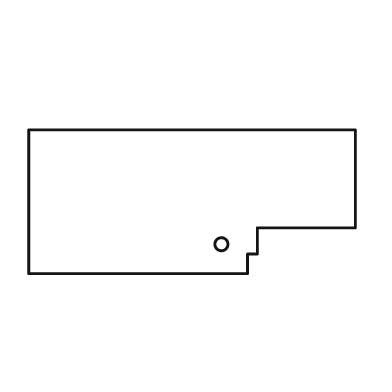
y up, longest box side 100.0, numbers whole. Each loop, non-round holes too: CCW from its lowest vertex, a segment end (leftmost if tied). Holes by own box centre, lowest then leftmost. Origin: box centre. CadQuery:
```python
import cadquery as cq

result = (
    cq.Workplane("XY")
    .moveTo(-50.0, -22.0)
    .lineTo(17.0, -22.0)
    .lineTo(17.0, -16.0)
    .lineTo(20.0, -16.0)
    .lineTo(20.0, -8.0)
    .lineTo(50.0, -8.0)
    .lineTo(50.0, 22.0)
    .lineTo(-50.0, 22.0)
    .close()
    .moveTo(9.0, -13.0)
    .circle(2.0)
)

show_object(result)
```